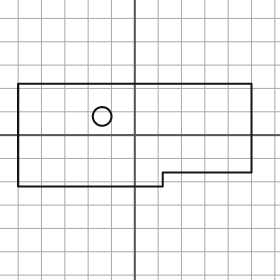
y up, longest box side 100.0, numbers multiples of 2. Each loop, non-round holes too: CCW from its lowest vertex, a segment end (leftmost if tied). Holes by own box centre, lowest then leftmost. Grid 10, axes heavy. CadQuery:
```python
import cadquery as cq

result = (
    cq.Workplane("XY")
    .moveTo(-50.0, -22.0)
    .lineTo(12.0, -22.0)
    .lineTo(12.0, -16.0)
    .lineTo(50.0, -16.0)
    .lineTo(50.0, 22.0)
    .lineTo(-50.0, 22.0)
    .close()
    .moveTo(-14.0, 8.0)
    .circle(4.0)
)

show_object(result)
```